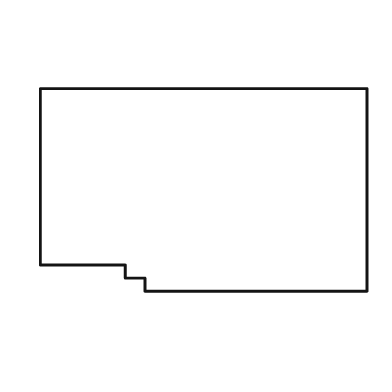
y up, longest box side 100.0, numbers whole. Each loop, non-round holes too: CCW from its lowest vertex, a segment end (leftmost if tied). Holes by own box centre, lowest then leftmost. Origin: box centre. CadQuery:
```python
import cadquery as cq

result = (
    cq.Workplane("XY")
    .moveTo(-18.0, -31.0)
    .lineTo(50.0, -31.0)
    .lineTo(50.0, 31.0)
    .lineTo(-50.0, 31.0)
    .lineTo(-50.0, -23.0)
    .lineTo(-24.0, -23.0)
    .lineTo(-24.0, -27.0)
    .lineTo(-18.0, -27.0)
    .close()
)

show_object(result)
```